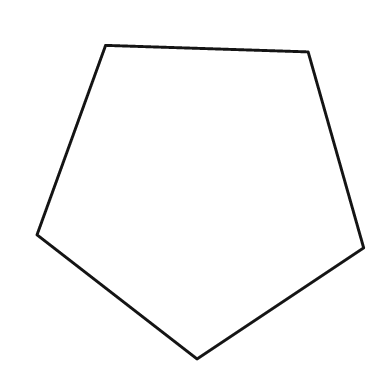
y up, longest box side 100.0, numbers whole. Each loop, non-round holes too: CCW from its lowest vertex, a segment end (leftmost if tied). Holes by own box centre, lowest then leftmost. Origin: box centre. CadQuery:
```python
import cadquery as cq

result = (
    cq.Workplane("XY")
    .moveTo(-1.0, -48.0)
    .lineTo(50.0, -14.0)
    .lineTo(33.0, 46.0)
    .lineTo(-29.0, 48.0)
    .lineTo(-50.0, -10.0)
    .close()
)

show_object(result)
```